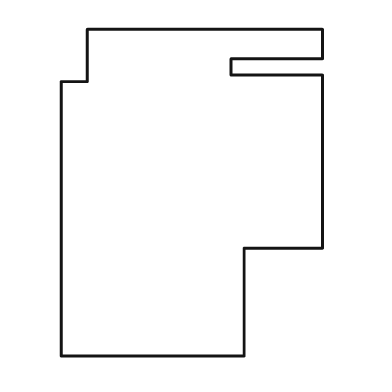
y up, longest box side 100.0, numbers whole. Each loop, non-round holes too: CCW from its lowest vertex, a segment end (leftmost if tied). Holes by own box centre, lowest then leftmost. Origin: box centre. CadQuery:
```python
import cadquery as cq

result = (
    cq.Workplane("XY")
    .moveTo(-40.0, -50.0)
    .lineTo(16.0, -50.0)
    .lineTo(16.0, -17.0)
    .lineTo(40.0, -17.0)
    .lineTo(40.0, 36.0)
    .lineTo(12.0, 36.0)
    .lineTo(12.0, 41.0)
    .lineTo(40.0, 41.0)
    .lineTo(40.0, 50.0)
    .lineTo(-32.0, 50.0)
    .lineTo(-32.0, 34.0)
    .lineTo(-40.0, 34.0)
    .close()
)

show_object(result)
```